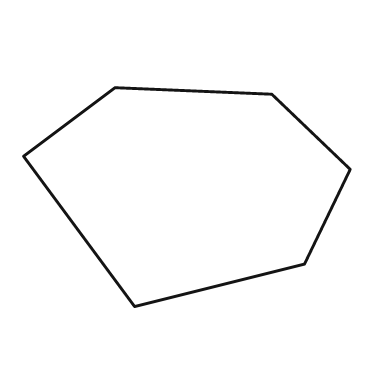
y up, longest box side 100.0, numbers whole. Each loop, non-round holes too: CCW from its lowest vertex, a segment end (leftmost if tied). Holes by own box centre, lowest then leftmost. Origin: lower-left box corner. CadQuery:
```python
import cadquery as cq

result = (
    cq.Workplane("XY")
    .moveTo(34.0, 0.0)
    .lineTo(86.0, 13.0)
    .lineTo(100.0, 42.0)
    .lineTo(76.0, 65.0)
    .lineTo(28.0, 67.0)
    .lineTo(0.0, 46.0)
    .close()
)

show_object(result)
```